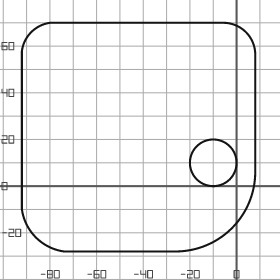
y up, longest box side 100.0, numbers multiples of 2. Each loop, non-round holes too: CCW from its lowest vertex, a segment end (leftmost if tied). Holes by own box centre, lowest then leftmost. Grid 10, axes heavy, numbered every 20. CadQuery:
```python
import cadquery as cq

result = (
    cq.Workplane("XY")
    .moveTo(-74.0, -28.0)
    .lineTo(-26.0, -28.0)
    .threePointArc((-2.0, -18.0), (8.0, 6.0))
    .lineTo(8.0, 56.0)
    .threePointArc((4.0, 66.0), (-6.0, 70.0))
    .lineTo(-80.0, 70.0)
    .threePointArc((-88.0, 66.0), (-92.0, 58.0))
    .lineTo(-92.0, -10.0)
    .threePointArc((-86.0, -22.0), (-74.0, -28.0))
    .close()
    .moveTo(-10.0, 10.0)
    .circle(10.0)
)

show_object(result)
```